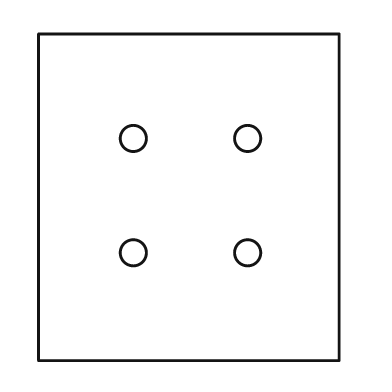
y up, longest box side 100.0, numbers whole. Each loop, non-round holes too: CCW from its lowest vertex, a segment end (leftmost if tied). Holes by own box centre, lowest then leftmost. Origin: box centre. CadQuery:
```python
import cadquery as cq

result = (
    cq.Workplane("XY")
    .moveTo(-46.0, -50.0)
    .lineTo(46.0, -50.0)
    .lineTo(46.0, 50.0)
    .lineTo(-46.0, 50.0)
    .close()
    .moveTo(-17.0, -17.0)
    .circle(4.0)
    .moveTo(18.0, -17.0)
    .circle(4.0)
    .moveTo(-17.0, 18.0)
    .circle(4.0)
    .moveTo(18.0, 18.0)
    .circle(4.0)
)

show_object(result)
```